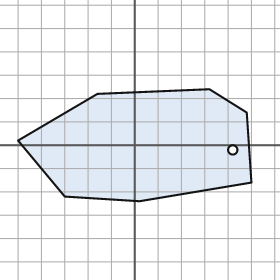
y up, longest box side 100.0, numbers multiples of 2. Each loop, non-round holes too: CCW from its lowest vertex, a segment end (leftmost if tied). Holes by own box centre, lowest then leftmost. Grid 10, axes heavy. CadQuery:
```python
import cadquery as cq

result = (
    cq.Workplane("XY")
    .moveTo(2.0, -24.0)
    .lineTo(50.0, -16.0)
    .lineTo(48.0, 14.0)
    .lineTo(32.0, 24.0)
    .lineTo(-16.0, 22.0)
    .lineTo(-50.0, 2.0)
    .lineTo(-30.0, -22.0)
    .close()
    .moveTo(42.0, -2.0)
    .circle(2.0)
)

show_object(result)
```